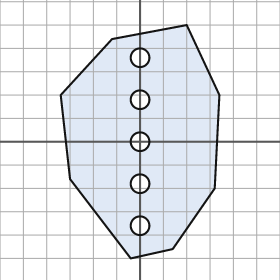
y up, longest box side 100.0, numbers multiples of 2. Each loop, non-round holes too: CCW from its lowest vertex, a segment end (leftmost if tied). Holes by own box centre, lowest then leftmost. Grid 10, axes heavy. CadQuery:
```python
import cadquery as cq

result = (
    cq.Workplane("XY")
    .moveTo(-4.0, -50.0)
    .lineTo(14.0, -46.0)
    .lineTo(32.0, -20.0)
    .lineTo(34.0, 20.0)
    .lineTo(20.0, 50.0)
    .lineTo(-12.0, 44.0)
    .lineTo(-34.0, 20.0)
    .lineTo(-30.0, -16.0)
    .close()
    .moveTo(0.0, -36.0)
    .circle(4.0)
    .moveTo(0.0, -18.0)
    .circle(4.0)
    .moveTo(0.0, 0.0)
    .circle(4.0)
    .moveTo(0.0, 18.0)
    .circle(4.0)
    .moveTo(0.0, 36.0)
    .circle(4.0)
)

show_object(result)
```